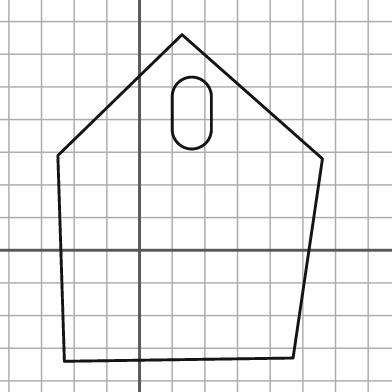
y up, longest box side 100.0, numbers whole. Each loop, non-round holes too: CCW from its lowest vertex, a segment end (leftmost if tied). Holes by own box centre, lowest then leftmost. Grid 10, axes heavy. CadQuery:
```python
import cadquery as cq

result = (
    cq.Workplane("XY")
    .moveTo(-23.0, -34.0)
    .lineTo(47.0, -33.0)
    .lineTo(56.0, 28.0)
    .lineTo(13.0, 66.0)
    .lineTo(-25.0, 29.0)
    .close()
    .moveTo(10.0, 37.0)
    .threePointArc((16.0, 31.0), (22.0, 37.0))
    .lineTo(22.0, 47.0)
    .threePointArc((16.0, 53.0), (10.0, 47.0))
    .close()
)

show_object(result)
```